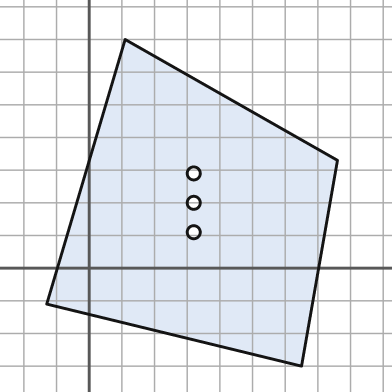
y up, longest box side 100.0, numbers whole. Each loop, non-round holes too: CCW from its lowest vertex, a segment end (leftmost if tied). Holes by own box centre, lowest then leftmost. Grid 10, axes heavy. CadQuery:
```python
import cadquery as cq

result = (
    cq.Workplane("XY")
    .moveTo(65.0, -30.0)
    .lineTo(76.0, 33.0)
    .lineTo(11.0, 70.0)
    .lineTo(-13.0, -11.0)
    .close()
    .moveTo(32.0, 11.0)
    .circle(2.0)
    .moveTo(32.0, 20.0)
    .circle(2.0)
    .moveTo(32.0, 29.0)
    .circle(2.0)
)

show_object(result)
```